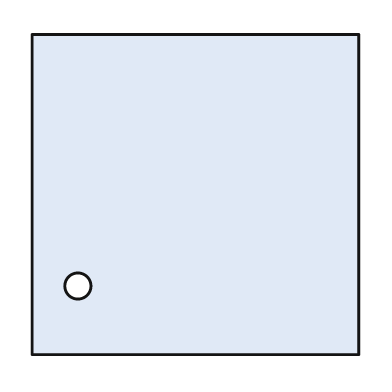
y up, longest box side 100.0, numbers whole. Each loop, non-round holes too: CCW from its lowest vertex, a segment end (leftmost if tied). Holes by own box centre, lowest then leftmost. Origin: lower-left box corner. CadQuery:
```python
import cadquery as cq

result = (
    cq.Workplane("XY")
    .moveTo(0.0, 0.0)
    .lineTo(100.0, 0.0)
    .lineTo(100.0, 98.0)
    .lineTo(0.0, 98.0)
    .close()
    .moveTo(14.0, 21.0)
    .circle(4.0)
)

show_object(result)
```